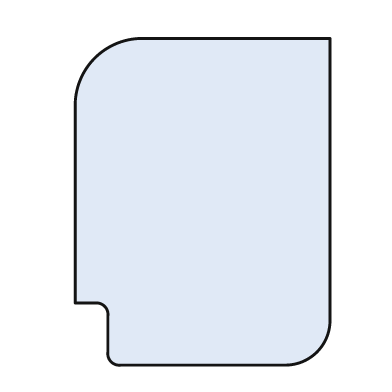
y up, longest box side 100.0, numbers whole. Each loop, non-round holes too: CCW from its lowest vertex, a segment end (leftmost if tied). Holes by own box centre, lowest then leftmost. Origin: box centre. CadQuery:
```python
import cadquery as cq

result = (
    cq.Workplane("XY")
    .moveTo(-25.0, -50.0)
    .lineTo(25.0, -50.0)
    .threePointArc((35.0, -46.0), (39.0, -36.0))
    .lineTo(39.0, 50.0)
    .lineTo(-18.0, 50.0)
    .threePointArc((-33.0, 44.0), (-39.0, 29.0))
    .lineTo(-39.0, -31.0)
    .lineTo(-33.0, -31.0)
    .threePointArc((-30.0, -32.0), (-29.0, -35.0))
    .lineTo(-29.0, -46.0)
    .threePointArc((-28.0, -49.0), (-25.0, -50.0))
    .close()
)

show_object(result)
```